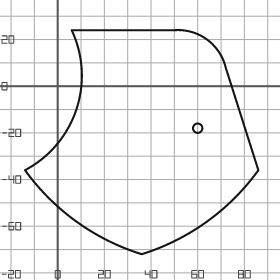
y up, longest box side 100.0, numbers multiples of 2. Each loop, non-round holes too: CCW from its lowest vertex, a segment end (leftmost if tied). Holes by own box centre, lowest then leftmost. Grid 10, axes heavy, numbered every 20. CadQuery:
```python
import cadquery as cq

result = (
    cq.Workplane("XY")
    .moveTo(36.0, -72.0)
    .threePointArc((64.0, -58.0), (86.0, -36.0))
    .lineTo(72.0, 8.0)
    .threePointArc((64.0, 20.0), (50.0, 24.0))
    .lineTo(6.0, 24.0)
    .threePointArc((8.0, -10.0), (-14.0, -36.0))
    .threePointArc((8.0, -58.0), (36.0, -72.0))
    .close()
    .moveTo(60.0, -18.0)
    .circle(2.0)
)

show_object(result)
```